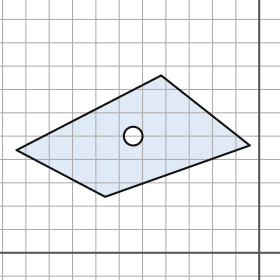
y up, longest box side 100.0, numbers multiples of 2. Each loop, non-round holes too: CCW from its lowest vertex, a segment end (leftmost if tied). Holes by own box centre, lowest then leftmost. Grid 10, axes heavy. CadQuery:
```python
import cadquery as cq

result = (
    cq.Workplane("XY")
    .moveTo(-66.0, 24.0)
    .lineTo(-4.0, 46.0)
    .lineTo(-42.0, 76.0)
    .lineTo(-104.0, 44.0)
    .close()
    .moveTo(-54.0, 50.0)
    .circle(4.0)
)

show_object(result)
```